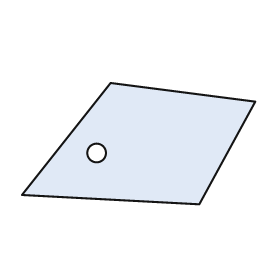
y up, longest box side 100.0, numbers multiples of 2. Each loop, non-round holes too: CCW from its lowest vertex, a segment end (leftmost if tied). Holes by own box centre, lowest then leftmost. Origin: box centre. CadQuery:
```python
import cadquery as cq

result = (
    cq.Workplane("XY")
    .moveTo(26.0, -26.0)
    .lineTo(50.0, 18.0)
    .lineTo(-12.0, 26.0)
    .lineTo(-50.0, -22.0)
    .close()
    .moveTo(-18.0, -4.0)
    .circle(4.0)
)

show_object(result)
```